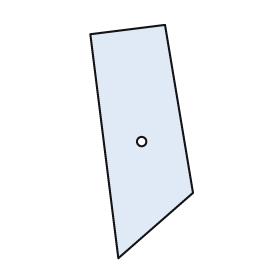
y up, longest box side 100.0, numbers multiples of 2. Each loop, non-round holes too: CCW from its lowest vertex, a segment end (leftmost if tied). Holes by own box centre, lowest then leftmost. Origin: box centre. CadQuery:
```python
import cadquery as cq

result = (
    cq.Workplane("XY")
    .moveTo(-10.0, -50.0)
    .lineTo(22.0, -22.0)
    .lineTo(10.0, 50.0)
    .lineTo(-22.0, 46.0)
    .close()
    .moveTo(0.0, 0.0)
    .circle(2.0)
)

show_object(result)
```